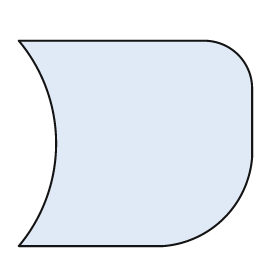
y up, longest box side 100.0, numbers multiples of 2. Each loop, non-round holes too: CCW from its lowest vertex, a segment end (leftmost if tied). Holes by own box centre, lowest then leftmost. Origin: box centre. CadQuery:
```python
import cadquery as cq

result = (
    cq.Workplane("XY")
    .moveTo(-50.0, -44.0)
    .lineTo(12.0, -44.0)
    .threePointArc((38.0, -32.0), (50.0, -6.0))
    .lineTo(50.0, 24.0)
    .threePointArc((44.0, 38.0), (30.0, 44.0))
    .lineTo(-50.0, 44.0)
    .threePointArc((-34.0, 0.0), (-50.0, -44.0))
    .close()
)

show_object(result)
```